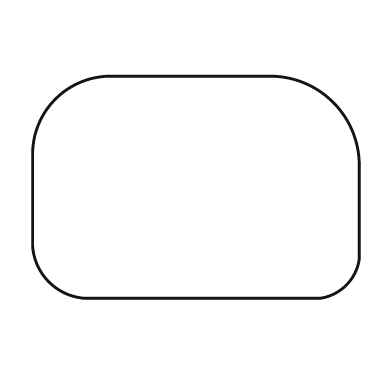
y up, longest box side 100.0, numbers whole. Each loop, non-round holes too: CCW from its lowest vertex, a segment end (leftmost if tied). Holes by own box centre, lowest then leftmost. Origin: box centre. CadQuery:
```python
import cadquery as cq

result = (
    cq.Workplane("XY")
    .moveTo(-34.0, -34.0)
    .lineTo(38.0, -34.0)
    .threePointArc((46.0, -30.0), (50.0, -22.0))
    .lineTo(50.0, 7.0)
    .threePointArc((42.0, 26.0), (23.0, 34.0))
    .lineTo(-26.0, 34.0)
    .threePointArc((-43.0, 27.0), (-50.0, 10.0))
    .lineTo(-50.0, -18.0)
    .threePointArc((-45.0, -29.0), (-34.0, -34.0))
    .close()
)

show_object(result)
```